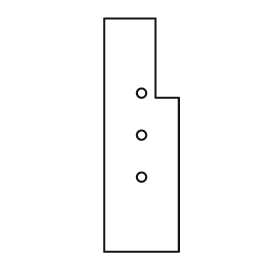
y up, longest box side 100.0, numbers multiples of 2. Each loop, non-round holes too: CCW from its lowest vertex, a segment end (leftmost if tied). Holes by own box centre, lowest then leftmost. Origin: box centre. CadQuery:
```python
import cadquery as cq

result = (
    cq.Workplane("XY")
    .moveTo(-16.0, -50.0)
    .lineTo(16.0, -50.0)
    .lineTo(16.0, 16.0)
    .lineTo(6.0, 16.0)
    .lineTo(6.0, 50.0)
    .lineTo(-16.0, 50.0)
    .close()
    .moveTo(0.0, -18.0)
    .circle(2.0)
    .moveTo(0.0, 0.0)
    .circle(2.0)
    .moveTo(0.0, 18.0)
    .circle(2.0)
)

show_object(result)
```